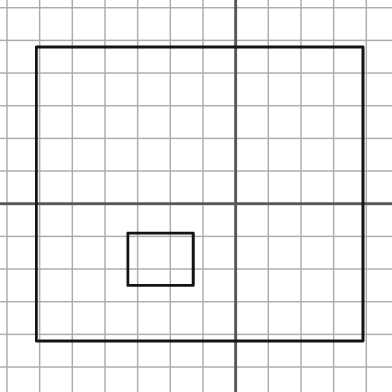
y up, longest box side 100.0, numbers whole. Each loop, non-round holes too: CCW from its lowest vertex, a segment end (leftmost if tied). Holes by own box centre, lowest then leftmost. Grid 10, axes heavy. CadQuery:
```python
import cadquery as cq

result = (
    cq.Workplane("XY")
    .moveTo(-61.0, -42.0)
    .lineTo(39.0, -42.0)
    .lineTo(39.0, 48.0)
    .lineTo(-61.0, 48.0)
    .close()
    .moveTo(-33.0, -25.0)
    .lineTo(-13.0, -25.0)
    .lineTo(-13.0, -9.0)
    .lineTo(-33.0, -9.0)
    .close()
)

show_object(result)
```